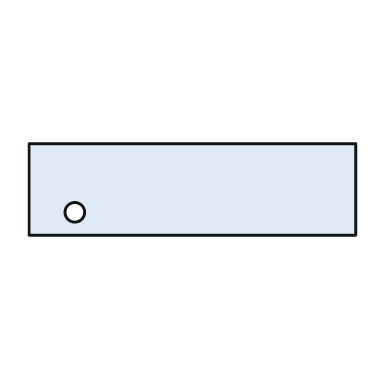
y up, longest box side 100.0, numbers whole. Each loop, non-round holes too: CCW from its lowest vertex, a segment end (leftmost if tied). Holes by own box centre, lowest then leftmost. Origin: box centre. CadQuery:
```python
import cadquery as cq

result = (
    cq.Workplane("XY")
    .moveTo(-50.0, -14.0)
    .lineTo(50.0, -14.0)
    .lineTo(50.0, 14.0)
    .lineTo(-50.0, 14.0)
    .close()
    .moveTo(-36.0, -7.0)
    .circle(3.0)
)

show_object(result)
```